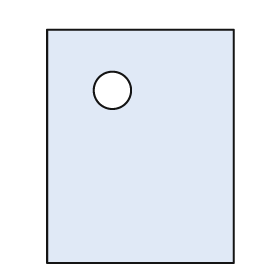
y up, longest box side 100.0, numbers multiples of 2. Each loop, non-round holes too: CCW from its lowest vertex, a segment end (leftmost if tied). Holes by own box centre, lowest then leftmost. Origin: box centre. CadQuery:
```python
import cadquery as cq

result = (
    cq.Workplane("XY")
    .moveTo(-40.0, -50.0)
    .lineTo(40.0, -50.0)
    .lineTo(40.0, 50.0)
    .lineTo(-40.0, 50.0)
    .close()
    .moveTo(-12.0, 24.0)
    .circle(8.0)
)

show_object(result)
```